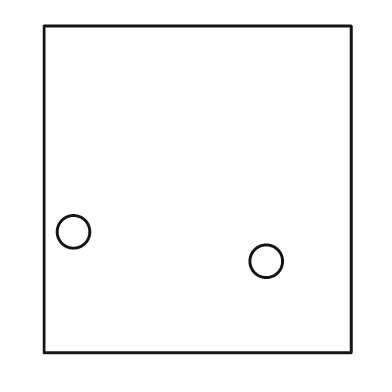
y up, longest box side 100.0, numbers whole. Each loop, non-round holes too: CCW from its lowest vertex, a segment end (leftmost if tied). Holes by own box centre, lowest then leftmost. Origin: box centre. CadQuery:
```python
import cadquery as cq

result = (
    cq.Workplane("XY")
    .moveTo(-47.0, -50.0)
    .lineTo(47.0, -50.0)
    .lineTo(47.0, 50.0)
    .lineTo(-47.0, 50.0)
    .close()
    .moveTo(21.0, -22.0)
    .circle(5.0)
    .moveTo(-38.0, -13.0)
    .circle(5.0)
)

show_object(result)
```